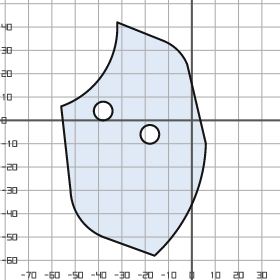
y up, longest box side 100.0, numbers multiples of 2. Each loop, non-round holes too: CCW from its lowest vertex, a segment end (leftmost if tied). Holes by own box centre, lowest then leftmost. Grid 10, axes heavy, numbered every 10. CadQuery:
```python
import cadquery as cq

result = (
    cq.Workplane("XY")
    .moveTo(-16.0, -58.0)
    .threePointArc((0.0, -36.0), (6.0, -10.0))
    .lineTo(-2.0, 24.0)
    .threePointArc((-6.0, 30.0), (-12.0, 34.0))
    .lineTo(-32.0, 42.0)
    .threePointArc((-38.0, 20.0), (-56.0, 6.0))
    .lineTo(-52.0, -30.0)
    .threePointArc((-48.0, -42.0), (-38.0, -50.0))
    .close()
    .moveTo(-18.0, -6.0)
    .circle(4.0)
    .moveTo(-38.0, 4.0)
    .circle(4.0)
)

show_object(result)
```